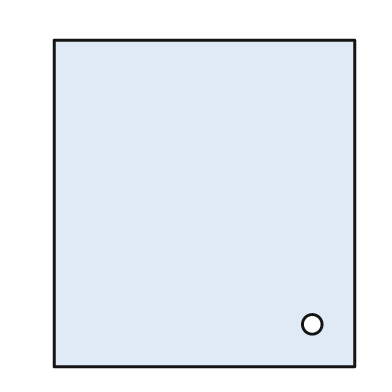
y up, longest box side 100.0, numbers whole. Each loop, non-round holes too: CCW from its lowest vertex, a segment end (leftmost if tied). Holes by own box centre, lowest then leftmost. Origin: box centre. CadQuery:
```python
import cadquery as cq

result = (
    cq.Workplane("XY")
    .moveTo(-46.0, -50.0)
    .lineTo(46.0, -50.0)
    .lineTo(46.0, 50.0)
    .lineTo(-46.0, 50.0)
    .close()
    .moveTo(33.0, -37.0)
    .circle(3.0)
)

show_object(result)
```